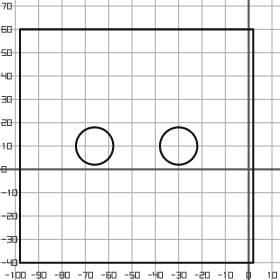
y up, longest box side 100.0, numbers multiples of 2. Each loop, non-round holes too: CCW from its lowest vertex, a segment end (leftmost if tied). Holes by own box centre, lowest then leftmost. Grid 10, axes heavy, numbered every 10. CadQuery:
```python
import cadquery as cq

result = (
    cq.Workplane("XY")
    .moveTo(-98.0, -40.0)
    .lineTo(2.0, -40.0)
    .lineTo(2.0, 60.0)
    .lineTo(-98.0, 60.0)
    .close()
    .moveTo(-66.0, 10.0)
    .circle(8.0)
    .moveTo(-30.0, 10.0)
    .circle(8.0)
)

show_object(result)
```